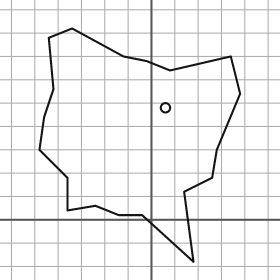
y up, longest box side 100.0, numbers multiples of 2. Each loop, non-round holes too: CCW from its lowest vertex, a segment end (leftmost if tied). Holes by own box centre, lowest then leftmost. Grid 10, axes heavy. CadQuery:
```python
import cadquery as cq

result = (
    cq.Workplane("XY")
    .moveTo(18.0, -18.0)
    .lineTo(14.0, 12.0)
    .lineTo(26.0, 18.0)
    .lineTo(28.0, 30.0)
    .lineTo(38.0, 54.0)
    .lineTo(34.0, 70.0)
    .lineTo(8.0, 64.0)
    .lineTo(-2.0, 68.0)
    .lineTo(-12.0, 70.0)
    .lineTo(-34.0, 82.0)
    .lineTo(-44.0, 78.0)
    .lineTo(-42.0, 56.0)
    .lineTo(-46.0, 44.0)
    .lineTo(-48.0, 30.0)
    .lineTo(-36.0, 18.0)
    .lineTo(-36.0, 4.0)
    .lineTo(-24.0, 6.0)
    .lineTo(-14.0, 2.0)
    .lineTo(-4.0, 2.0)
    .close()
    .moveTo(6.0, 48.0)
    .circle(2.0)
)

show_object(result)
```